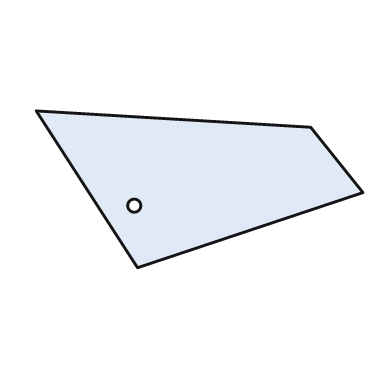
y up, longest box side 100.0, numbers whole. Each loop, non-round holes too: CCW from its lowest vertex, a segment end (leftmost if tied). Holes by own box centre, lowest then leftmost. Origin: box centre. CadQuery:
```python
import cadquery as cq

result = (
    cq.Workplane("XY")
    .moveTo(-19.0, -24.0)
    .lineTo(50.0, -1.0)
    .lineTo(34.0, 19.0)
    .lineTo(-50.0, 24.0)
    .close()
    .moveTo(-20.0, -5.0)
    .circle(2.0)
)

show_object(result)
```